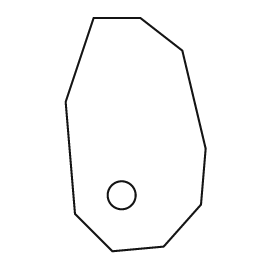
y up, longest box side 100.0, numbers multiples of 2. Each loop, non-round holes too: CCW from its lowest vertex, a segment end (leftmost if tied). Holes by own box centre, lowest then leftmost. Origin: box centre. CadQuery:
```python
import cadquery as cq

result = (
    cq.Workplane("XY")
    .moveTo(-10.0, -50.0)
    .lineTo(12.0, -48.0)
    .lineTo(28.0, -30.0)
    .lineTo(30.0, -6.0)
    .lineTo(20.0, 36.0)
    .lineTo(2.0, 50.0)
    .lineTo(-18.0, 50.0)
    .lineTo(-30.0, 14.0)
    .lineTo(-26.0, -34.0)
    .close()
    .moveTo(-6.0, -26.0)
    .circle(6.0)
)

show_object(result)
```